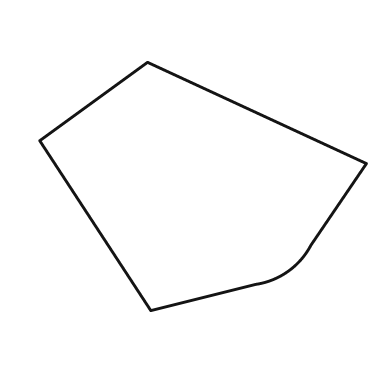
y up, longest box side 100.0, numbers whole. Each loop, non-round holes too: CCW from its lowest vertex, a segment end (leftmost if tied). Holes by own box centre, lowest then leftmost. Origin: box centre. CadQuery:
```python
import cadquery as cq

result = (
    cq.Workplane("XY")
    .moveTo(-16.0, -38.0)
    .lineTo(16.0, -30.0)
    .threePointArc((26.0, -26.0), (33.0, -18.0))
    .lineTo(50.0, 7.0)
    .lineTo(-17.0, 38.0)
    .lineTo(-50.0, 14.0)
    .close()
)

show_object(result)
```